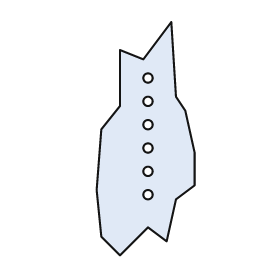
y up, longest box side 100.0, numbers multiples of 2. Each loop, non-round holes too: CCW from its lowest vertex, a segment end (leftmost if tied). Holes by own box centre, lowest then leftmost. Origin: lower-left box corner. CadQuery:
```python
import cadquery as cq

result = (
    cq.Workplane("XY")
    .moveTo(10.0, 0.0)
    .lineTo(22.0, 12.0)
    .lineTo(30.0, 6.0)
    .lineTo(34.0, 24.0)
    .lineTo(42.0, 30.0)
    .lineTo(42.0, 44.0)
    .lineTo(38.0, 62.0)
    .lineTo(34.0, 68.0)
    .lineTo(32.0, 100.0)
    .lineTo(20.0, 84.0)
    .lineTo(10.0, 88.0)
    .lineTo(10.0, 64.0)
    .lineTo(2.0, 54.0)
    .lineTo(0.0, 28.0)
    .lineTo(2.0, 8.0)
    .close()
    .moveTo(22.0, 26.0)
    .circle(2.0)
    .moveTo(22.0, 36.0)
    .circle(2.0)
    .moveTo(22.0, 46.0)
    .circle(2.0)
    .moveTo(22.0, 56.0)
    .circle(2.0)
    .moveTo(22.0, 66.0)
    .circle(2.0)
    .moveTo(22.0, 76.0)
    .circle(2.0)
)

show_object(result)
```